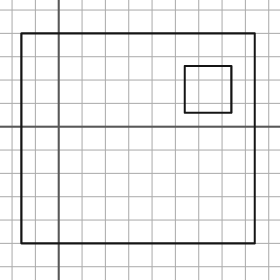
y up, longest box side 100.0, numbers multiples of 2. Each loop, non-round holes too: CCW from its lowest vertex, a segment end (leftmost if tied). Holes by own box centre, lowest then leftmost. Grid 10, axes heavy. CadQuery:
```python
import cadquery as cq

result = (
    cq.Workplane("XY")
    .moveTo(-16.0, -50.0)
    .lineTo(84.0, -50.0)
    .lineTo(84.0, 40.0)
    .lineTo(-16.0, 40.0)
    .close()
    .moveTo(54.0, 6.0)
    .lineTo(74.0, 6.0)
    .lineTo(74.0, 26.0)
    .lineTo(54.0, 26.0)
    .close()
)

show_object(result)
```